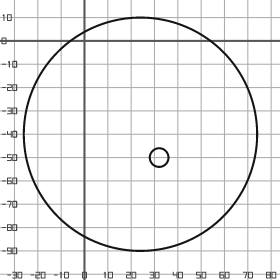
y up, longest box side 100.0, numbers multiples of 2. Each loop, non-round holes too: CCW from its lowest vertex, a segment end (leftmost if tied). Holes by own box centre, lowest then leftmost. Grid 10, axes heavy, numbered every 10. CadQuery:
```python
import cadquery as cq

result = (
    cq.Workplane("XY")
    .moveTo(24.0, -40.0)
    .circle(50.0)
    .moveTo(32.0, -50.0)
    .circle(4.0)
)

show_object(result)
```